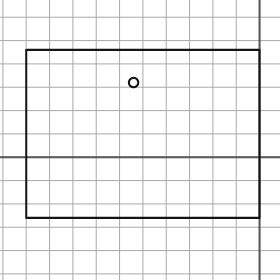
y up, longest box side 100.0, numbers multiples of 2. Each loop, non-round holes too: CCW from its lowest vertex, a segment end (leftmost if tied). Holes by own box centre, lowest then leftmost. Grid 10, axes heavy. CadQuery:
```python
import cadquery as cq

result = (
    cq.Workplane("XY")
    .moveTo(-100.0, -26.0)
    .lineTo(0.0, -26.0)
    .lineTo(0.0, 46.0)
    .lineTo(-100.0, 46.0)
    .close()
    .moveTo(-54.0, 32.0)
    .circle(2.0)
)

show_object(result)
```